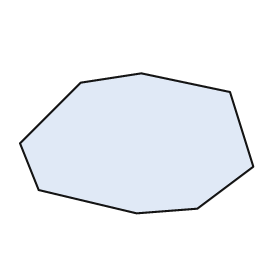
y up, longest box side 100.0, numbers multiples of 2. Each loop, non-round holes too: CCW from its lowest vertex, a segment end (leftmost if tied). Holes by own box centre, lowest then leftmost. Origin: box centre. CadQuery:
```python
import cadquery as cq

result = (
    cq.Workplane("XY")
    .moveTo(0.0, -30.0)
    .lineTo(26.0, -28.0)
    .lineTo(50.0, -10.0)
    .lineTo(40.0, 22.0)
    .lineTo(2.0, 30.0)
    .lineTo(-24.0, 26.0)
    .lineTo(-50.0, 0.0)
    .lineTo(-42.0, -20.0)
    .close()
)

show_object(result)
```